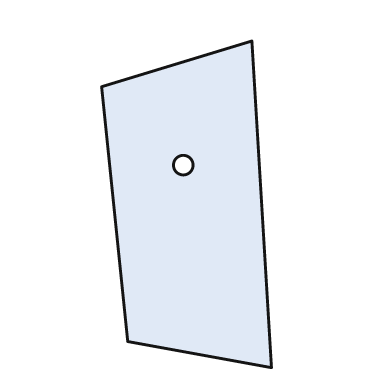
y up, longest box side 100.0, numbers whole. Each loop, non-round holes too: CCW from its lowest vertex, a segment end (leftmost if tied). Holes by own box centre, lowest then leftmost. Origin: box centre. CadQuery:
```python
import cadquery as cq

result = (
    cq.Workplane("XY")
    .moveTo(26.0, -50.0)
    .lineTo(20.0, 50.0)
    .lineTo(-26.0, 36.0)
    .lineTo(-18.0, -42.0)
    .close()
    .moveTo(-1.0, 12.0)
    .circle(3.0)
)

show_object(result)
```